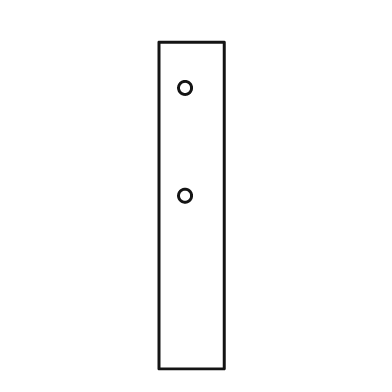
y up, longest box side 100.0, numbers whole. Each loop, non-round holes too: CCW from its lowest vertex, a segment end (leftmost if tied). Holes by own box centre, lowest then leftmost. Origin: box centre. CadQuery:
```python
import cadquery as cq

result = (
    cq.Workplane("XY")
    .moveTo(-10.0, -50.0)
    .lineTo(10.0, -50.0)
    .lineTo(10.0, 50.0)
    .lineTo(-10.0, 50.0)
    .close()
    .moveTo(-2.0, 3.0)
    .circle(2.0)
    .moveTo(-2.0, 36.0)
    .circle(2.0)
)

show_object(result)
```